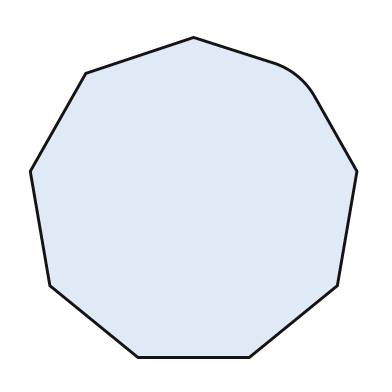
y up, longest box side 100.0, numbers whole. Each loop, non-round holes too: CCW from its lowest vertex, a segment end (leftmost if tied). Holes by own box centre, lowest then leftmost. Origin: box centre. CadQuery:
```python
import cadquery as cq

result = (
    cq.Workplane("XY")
    .moveTo(-17.0, -49.0)
    .lineTo(17.0, -49.0)
    .lineTo(44.0, -27.0)
    .lineTo(50.0, 8.0)
    .lineTo(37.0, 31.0)
    .threePointArc((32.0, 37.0), (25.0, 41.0))
    .lineTo(0.0, 49.0)
    .lineTo(-33.0, 38.0)
    .lineTo(-50.0, 8.0)
    .lineTo(-44.0, -27.0)
    .close()
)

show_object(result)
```